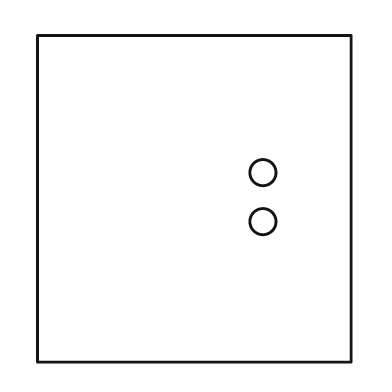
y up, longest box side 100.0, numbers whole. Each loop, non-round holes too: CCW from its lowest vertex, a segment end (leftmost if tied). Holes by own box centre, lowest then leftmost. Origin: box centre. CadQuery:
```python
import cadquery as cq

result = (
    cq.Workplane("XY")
    .moveTo(-48.0, -50.0)
    .lineTo(48.0, -50.0)
    .lineTo(48.0, 50.0)
    .lineTo(-48.0, 50.0)
    .close()
    .moveTo(21.0, -7.0)
    .circle(4.0)
    .moveTo(21.0, 8.0)
    .circle(4.0)
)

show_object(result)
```